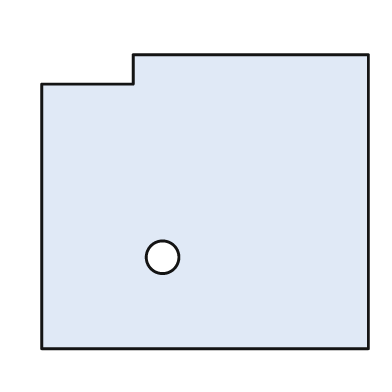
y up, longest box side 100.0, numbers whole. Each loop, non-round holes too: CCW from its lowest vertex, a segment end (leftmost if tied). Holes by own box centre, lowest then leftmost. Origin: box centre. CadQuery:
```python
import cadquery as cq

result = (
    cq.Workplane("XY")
    .moveTo(-50.0, -45.0)
    .lineTo(50.0, -45.0)
    .lineTo(50.0, 45.0)
    .lineTo(-22.0, 45.0)
    .lineTo(-22.0, 36.0)
    .lineTo(-50.0, 36.0)
    .close()
    .moveTo(-13.0, -17.0)
    .circle(5.0)
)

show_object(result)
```